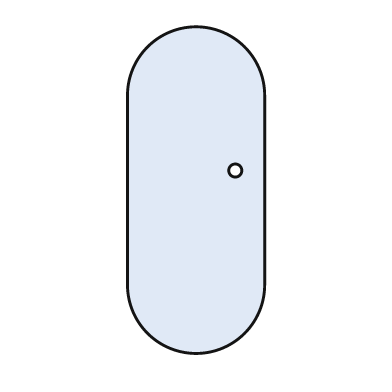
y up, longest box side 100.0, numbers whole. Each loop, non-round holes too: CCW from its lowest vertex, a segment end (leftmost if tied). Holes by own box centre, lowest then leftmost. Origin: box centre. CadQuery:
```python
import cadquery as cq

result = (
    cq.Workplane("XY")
    .moveTo(-21.0, -29.0)
    .threePointArc((0.0, -50.0), (21.0, -29.0))
    .lineTo(21.0, 29.0)
    .threePointArc((0.0, 50.0), (-21.0, 29.0))
    .close()
    .moveTo(12.0, 6.0)
    .circle(2.0)
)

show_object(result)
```